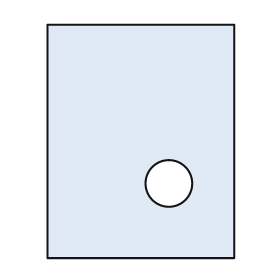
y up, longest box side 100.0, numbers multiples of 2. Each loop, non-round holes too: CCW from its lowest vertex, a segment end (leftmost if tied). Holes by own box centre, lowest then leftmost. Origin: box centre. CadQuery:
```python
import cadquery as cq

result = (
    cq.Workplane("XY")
    .moveTo(-40.0, -50.0)
    .lineTo(40.0, -50.0)
    .lineTo(40.0, 50.0)
    .lineTo(-40.0, 50.0)
    .close()
    .moveTo(12.0, -18.0)
    .circle(10.0)
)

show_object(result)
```